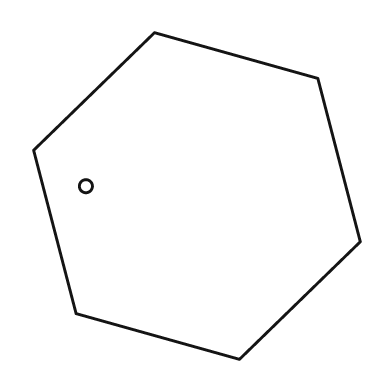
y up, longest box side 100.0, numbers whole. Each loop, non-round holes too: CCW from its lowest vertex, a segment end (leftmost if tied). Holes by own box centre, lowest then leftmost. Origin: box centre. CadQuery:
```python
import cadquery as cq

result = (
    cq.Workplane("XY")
    .moveTo(13.0, -50.0)
    .lineTo(50.0, -14.0)
    .lineTo(37.0, 36.0)
    .lineTo(-13.0, 50.0)
    .lineTo(-50.0, 14.0)
    .lineTo(-37.0, -36.0)
    .close()
    .moveTo(-34.0, 3.0)
    .circle(2.0)
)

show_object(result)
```